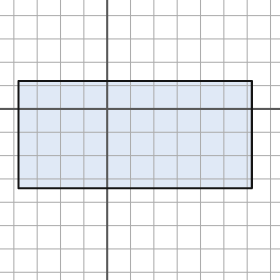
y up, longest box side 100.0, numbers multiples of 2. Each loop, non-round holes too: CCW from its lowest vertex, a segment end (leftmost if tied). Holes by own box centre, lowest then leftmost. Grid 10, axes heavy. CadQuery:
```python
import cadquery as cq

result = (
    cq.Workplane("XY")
    .moveTo(-38.0, -34.0)
    .lineTo(62.0, -34.0)
    .lineTo(62.0, 12.0)
    .lineTo(-38.0, 12.0)
    .close()
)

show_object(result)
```